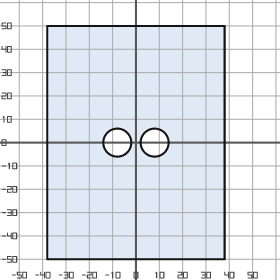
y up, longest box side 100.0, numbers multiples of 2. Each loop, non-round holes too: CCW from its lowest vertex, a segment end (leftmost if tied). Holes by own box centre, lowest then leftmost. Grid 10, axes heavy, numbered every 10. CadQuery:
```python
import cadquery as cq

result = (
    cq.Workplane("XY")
    .moveTo(-38.0, -50.0)
    .lineTo(38.0, -50.0)
    .lineTo(38.0, 50.0)
    .lineTo(-38.0, 50.0)
    .close()
    .moveTo(-8.0, 0.0)
    .circle(6.0)
    .moveTo(8.0, 0.0)
    .circle(6.0)
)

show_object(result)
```